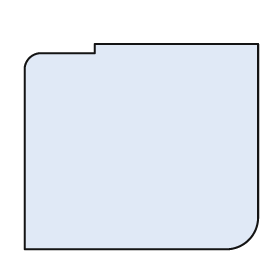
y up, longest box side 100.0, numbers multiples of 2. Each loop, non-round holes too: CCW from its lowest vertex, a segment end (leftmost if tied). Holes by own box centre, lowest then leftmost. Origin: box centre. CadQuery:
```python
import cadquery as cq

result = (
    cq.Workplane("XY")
    .moveTo(-50.0, -44.0)
    .lineTo(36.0, -44.0)
    .threePointArc((46.0, -40.0), (50.0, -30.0))
    .lineTo(50.0, 44.0)
    .lineTo(-20.0, 44.0)
    .lineTo(-20.0, 40.0)
    .lineTo(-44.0, 40.0)
    .threePointArc((-48.0, 38.0), (-50.0, 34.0))
    .close()
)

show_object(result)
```